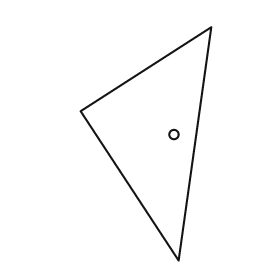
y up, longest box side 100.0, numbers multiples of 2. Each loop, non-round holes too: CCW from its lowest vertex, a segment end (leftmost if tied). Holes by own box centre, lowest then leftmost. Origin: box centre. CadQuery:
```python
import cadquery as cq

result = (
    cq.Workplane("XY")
    .moveTo(14.0, -50.0)
    .lineTo(28.0, 50.0)
    .lineTo(-28.0, 14.0)
    .close()
    .moveTo(12.0, 4.0)
    .circle(2.0)
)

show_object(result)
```